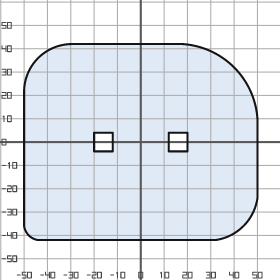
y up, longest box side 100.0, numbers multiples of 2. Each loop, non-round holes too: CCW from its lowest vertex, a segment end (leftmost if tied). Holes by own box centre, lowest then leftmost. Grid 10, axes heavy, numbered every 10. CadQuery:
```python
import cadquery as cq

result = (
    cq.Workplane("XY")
    .moveTo(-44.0, -42.0)
    .lineTo(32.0, -42.0)
    .threePointArc((44.0, -36.0), (50.0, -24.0))
    .lineTo(50.0, 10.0)
    .threePointArc((40.0, 32.0), (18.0, 42.0))
    .lineTo(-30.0, 42.0)
    .threePointArc((-44.0, 36.0), (-50.0, 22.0))
    .lineTo(-50.0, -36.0)
    .threePointArc((-48.0, -40.0), (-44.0, -42.0))
    .close()
    .moveTo(-20.0, -4.0)
    .lineTo(-12.0, -4.0)
    .lineTo(-12.0, 4.0)
    .lineTo(-20.0, 4.0)
    .close()
    .moveTo(12.0, -4.0)
    .lineTo(20.0, -4.0)
    .lineTo(20.0, 4.0)
    .lineTo(12.0, 4.0)
    .close()
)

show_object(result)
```